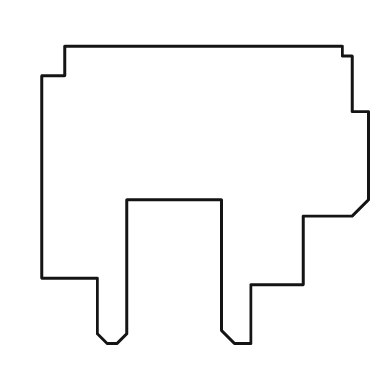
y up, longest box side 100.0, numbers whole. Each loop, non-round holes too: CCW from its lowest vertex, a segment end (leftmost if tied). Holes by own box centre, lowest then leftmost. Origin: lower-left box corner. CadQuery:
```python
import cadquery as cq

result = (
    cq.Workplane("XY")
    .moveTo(20.0, 0.0)
    .lineTo(23.0, 0.0)
    .lineTo(26.0, 3.0)
    .lineTo(26.0, 44.0)
    .lineTo(55.0, 44.0)
    .lineTo(55.0, 4.0)
    .lineTo(59.0, 0.0)
    .lineTo(64.0, 0.0)
    .lineTo(64.0, 18.0)
    .lineTo(80.0, 18.0)
    .lineTo(80.0, 39.0)
    .lineTo(95.0, 39.0)
    .lineTo(100.0, 44.0)
    .lineTo(100.0, 71.0)
    .lineTo(95.0, 71.0)
    .lineTo(95.0, 88.0)
    .lineTo(92.0, 88.0)
    .lineTo(92.0, 91.0)
    .lineTo(7.0, 91.0)
    .lineTo(7.0, 82.0)
    .lineTo(0.0, 82.0)
    .lineTo(0.0, 20.0)
    .lineTo(17.0, 20.0)
    .lineTo(17.0, 3.0)
    .close()
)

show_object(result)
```